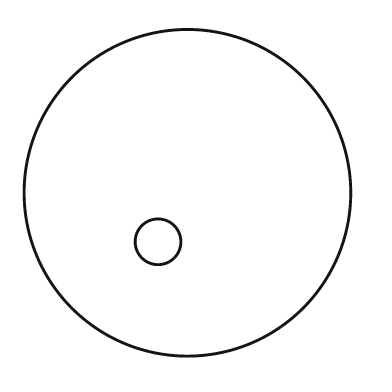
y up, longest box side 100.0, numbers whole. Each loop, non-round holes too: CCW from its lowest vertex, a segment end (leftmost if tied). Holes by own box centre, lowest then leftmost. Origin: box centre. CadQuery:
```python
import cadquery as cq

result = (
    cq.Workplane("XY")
    .moveTo(0.0, 0.0)
    .circle(50.0)
    .moveTo(-9.0, -15.0)
    .circle(7.0)
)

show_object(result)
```